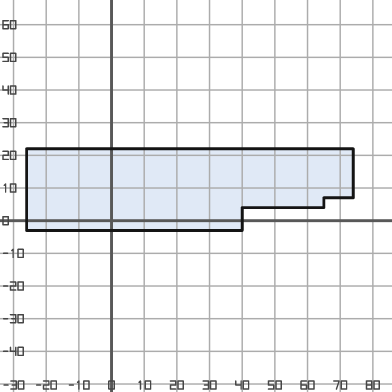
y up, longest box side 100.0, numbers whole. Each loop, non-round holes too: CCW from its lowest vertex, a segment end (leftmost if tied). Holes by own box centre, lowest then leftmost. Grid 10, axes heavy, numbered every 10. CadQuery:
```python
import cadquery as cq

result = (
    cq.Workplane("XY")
    .moveTo(-26.0, -3.0)
    .lineTo(40.0, -3.0)
    .lineTo(40.0, 4.0)
    .lineTo(65.0, 4.0)
    .lineTo(65.0, 7.0)
    .lineTo(74.0, 7.0)
    .lineTo(74.0, 22.0)
    .lineTo(-26.0, 22.0)
    .close()
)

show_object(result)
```